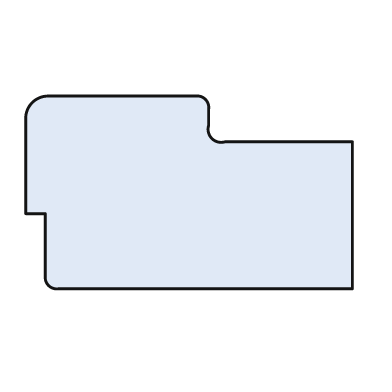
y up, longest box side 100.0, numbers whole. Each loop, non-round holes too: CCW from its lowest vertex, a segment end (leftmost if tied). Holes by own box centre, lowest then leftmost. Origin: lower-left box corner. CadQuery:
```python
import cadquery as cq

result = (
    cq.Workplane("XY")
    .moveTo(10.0, 0.0)
    .lineTo(100.0, 0.0)
    .lineTo(100.0, 45.0)
    .lineTo(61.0, 45.0)
    .threePointArc((57.0, 46.0), (56.0, 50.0))
    .lineTo(56.0, 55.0)
    .threePointArc((55.0, 58.0), (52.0, 59.0))
    .lineTo(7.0, 59.0)
    .threePointArc((2.0, 57.0), (0.0, 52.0))
    .lineTo(0.0, 23.0)
    .lineTo(6.0, 23.0)
    .lineTo(6.0, 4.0)
    .threePointArc((7.0, 1.0), (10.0, 0.0))
    .close()
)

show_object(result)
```